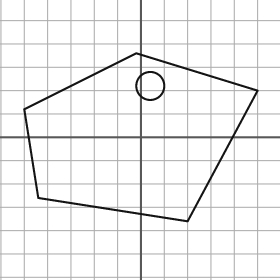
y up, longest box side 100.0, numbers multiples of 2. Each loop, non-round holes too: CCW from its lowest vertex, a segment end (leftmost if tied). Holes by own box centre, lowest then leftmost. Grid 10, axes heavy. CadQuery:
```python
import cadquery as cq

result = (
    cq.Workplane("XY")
    .moveTo(20.0, -36.0)
    .lineTo(50.0, 20.0)
    .lineTo(-2.0, 36.0)
    .lineTo(-50.0, 12.0)
    .lineTo(-44.0, -26.0)
    .close()
    .moveTo(4.0, 22.0)
    .circle(6.0)
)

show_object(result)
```